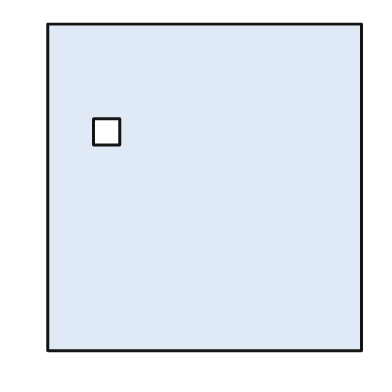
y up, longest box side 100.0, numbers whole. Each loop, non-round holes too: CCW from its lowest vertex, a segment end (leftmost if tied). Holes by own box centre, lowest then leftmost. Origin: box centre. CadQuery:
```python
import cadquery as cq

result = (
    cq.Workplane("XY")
    .moveTo(-48.0, -50.0)
    .lineTo(48.0, -50.0)
    .lineTo(48.0, 50.0)
    .lineTo(-48.0, 50.0)
    .close()
    .moveTo(-34.0, 13.0)
    .lineTo(-26.0, 13.0)
    .lineTo(-26.0, 21.0)
    .lineTo(-34.0, 21.0)
    .close()
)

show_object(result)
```